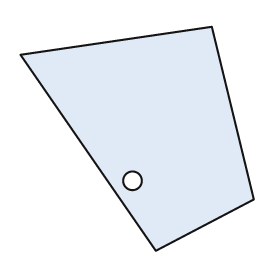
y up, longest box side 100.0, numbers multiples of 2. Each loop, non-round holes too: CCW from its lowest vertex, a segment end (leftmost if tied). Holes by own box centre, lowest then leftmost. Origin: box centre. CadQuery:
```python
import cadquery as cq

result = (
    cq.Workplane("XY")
    .moveTo(8.0, -48.0)
    .lineTo(50.0, -26.0)
    .lineTo(32.0, 48.0)
    .lineTo(-50.0, 36.0)
    .close()
    .moveTo(-2.0, -18.0)
    .circle(4.0)
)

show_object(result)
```